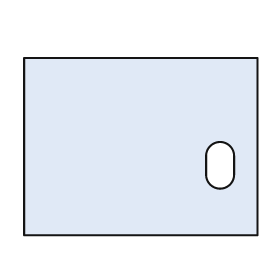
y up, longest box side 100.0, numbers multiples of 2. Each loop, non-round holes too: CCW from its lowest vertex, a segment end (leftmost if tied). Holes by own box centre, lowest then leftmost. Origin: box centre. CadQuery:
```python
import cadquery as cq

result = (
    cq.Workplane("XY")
    .moveTo(-50.0, -38.0)
    .lineTo(50.0, -38.0)
    .lineTo(50.0, 38.0)
    .lineTo(-50.0, 38.0)
    .close()
    .moveTo(28.0, -12.0)
    .threePointArc((34.0, -18.0), (40.0, -12.0))
    .lineTo(40.0, -4.0)
    .threePointArc((34.0, 2.0), (28.0, -4.0))
    .close()
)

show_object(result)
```